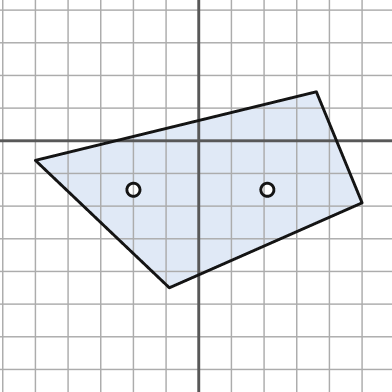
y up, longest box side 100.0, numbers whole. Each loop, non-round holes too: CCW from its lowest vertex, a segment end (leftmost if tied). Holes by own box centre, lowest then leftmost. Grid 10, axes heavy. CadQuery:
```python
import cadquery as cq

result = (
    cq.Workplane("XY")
    .moveTo(-9.0, -45.0)
    .lineTo(50.0, -19.0)
    .lineTo(36.0, 15.0)
    .lineTo(-50.0, -6.0)
    .close()
    .moveTo(-20.0, -15.0)
    .circle(2.0)
    .moveTo(21.0, -15.0)
    .circle(2.0)
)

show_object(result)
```